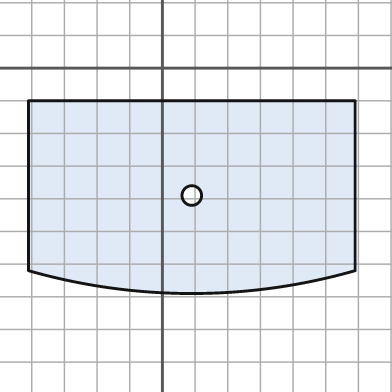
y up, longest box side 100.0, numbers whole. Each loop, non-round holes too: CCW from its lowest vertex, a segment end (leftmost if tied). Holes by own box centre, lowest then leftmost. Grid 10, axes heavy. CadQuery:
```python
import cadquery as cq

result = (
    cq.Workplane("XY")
    .moveTo(-41.0, -62.0)
    .threePointArc((9.0, -69.0), (59.0, -62.0))
    .lineTo(59.0, -10.0)
    .lineTo(-41.0, -10.0)
    .close()
    .moveTo(9.0, -39.0)
    .circle(3.0)
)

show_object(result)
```